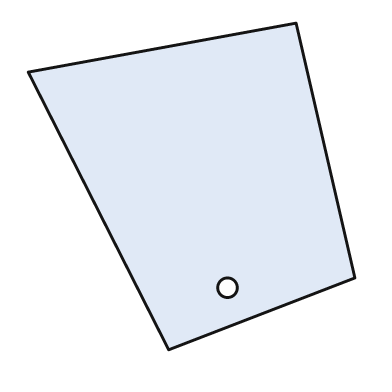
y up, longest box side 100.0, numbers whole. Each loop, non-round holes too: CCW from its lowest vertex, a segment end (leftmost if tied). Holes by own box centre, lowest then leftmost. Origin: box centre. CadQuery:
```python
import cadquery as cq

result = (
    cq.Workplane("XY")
    .moveTo(-7.0, -50.0)
    .lineTo(50.0, -28.0)
    .lineTo(32.0, 50.0)
    .lineTo(-50.0, 35.0)
    .close()
    .moveTo(11.0, -31.0)
    .circle(3.0)
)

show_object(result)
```